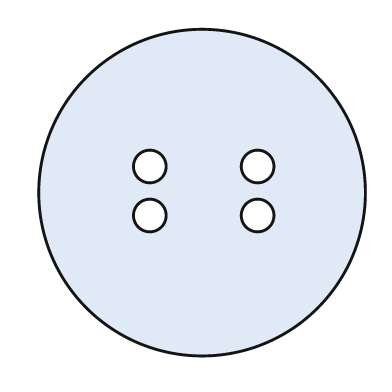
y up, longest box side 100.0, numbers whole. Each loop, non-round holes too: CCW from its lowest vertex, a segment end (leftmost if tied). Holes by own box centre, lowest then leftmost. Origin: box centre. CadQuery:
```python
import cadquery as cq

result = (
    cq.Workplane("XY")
    .moveTo(0.0, 0.0)
    .circle(50.0)
    .moveTo(-16.0, -7.0)
    .circle(5.0)
    .moveTo(17.0, -7.0)
    .circle(5.0)
    .moveTo(-16.0, 8.0)
    .circle(5.0)
    .moveTo(17.0, 8.0)
    .circle(5.0)
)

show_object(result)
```